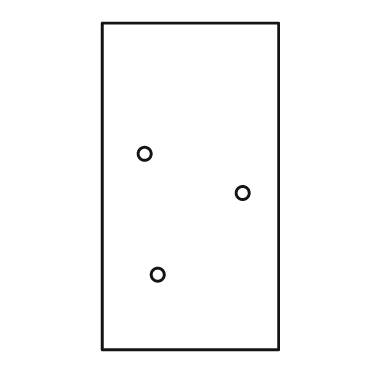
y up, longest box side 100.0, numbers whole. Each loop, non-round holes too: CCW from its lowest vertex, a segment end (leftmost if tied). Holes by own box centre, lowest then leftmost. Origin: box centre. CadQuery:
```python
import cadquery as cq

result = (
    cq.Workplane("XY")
    .moveTo(-27.0, -50.0)
    .lineTo(27.0, -50.0)
    .lineTo(27.0, 50.0)
    .lineTo(-27.0, 50.0)
    .close()
    .moveTo(-10.0, -27.0)
    .circle(2.0)
    .moveTo(16.0, -2.0)
    .circle(2.0)
    .moveTo(-14.0, 10.0)
    .circle(2.0)
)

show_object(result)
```